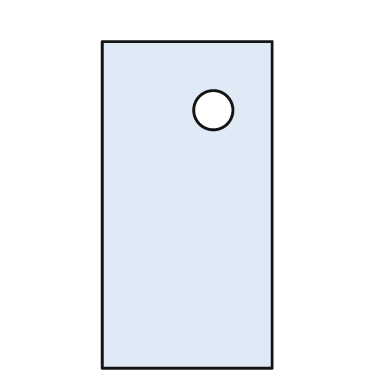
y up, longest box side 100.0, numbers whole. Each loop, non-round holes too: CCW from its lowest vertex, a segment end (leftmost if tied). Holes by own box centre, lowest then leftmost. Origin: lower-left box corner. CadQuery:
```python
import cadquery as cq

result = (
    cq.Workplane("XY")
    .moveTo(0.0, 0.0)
    .lineTo(52.0, 0.0)
    .lineTo(52.0, 100.0)
    .lineTo(0.0, 100.0)
    .close()
    .moveTo(34.0, 79.0)
    .circle(6.0)
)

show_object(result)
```